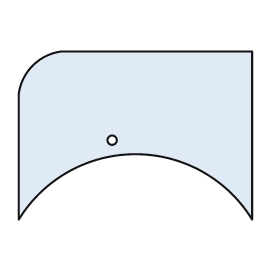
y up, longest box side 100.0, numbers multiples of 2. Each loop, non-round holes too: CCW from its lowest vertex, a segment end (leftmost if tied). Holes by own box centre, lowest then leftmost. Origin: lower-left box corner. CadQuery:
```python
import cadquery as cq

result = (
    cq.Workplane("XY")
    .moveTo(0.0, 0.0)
    .threePointArc((50.0, 28.0), (100.0, 0.0))
    .lineTo(100.0, 72.0)
    .lineTo(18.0, 72.0)
    .threePointArc((6.0, 66.0), (0.0, 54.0))
    .close()
    .moveTo(40.0, 34.0)
    .circle(2.0)
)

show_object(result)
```